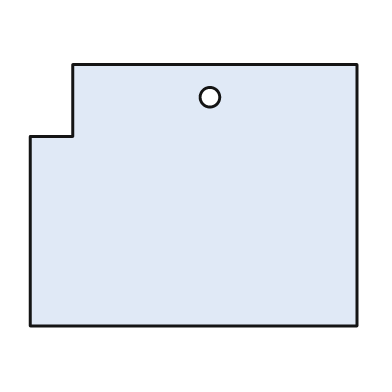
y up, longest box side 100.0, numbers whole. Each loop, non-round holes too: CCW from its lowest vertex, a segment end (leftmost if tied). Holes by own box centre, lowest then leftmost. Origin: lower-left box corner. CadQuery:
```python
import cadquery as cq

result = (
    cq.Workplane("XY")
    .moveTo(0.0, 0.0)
    .lineTo(100.0, 0.0)
    .lineTo(100.0, 80.0)
    .lineTo(13.0, 80.0)
    .lineTo(13.0, 58.0)
    .lineTo(0.0, 58.0)
    .close()
    .moveTo(55.0, 70.0)
    .circle(3.0)
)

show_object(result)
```